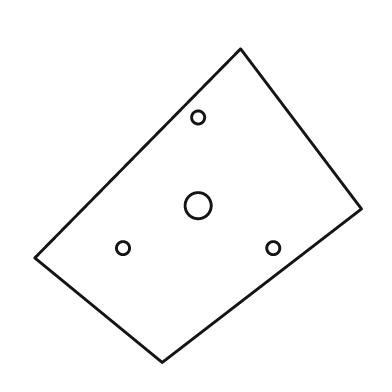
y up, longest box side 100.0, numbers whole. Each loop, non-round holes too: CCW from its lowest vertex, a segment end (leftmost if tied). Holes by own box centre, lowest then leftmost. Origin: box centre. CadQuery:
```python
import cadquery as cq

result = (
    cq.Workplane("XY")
    .moveTo(-11.0, -48.0)
    .lineTo(50.0, -1.0)
    .lineTo(13.0, 48.0)
    .lineTo(-50.0, -16.0)
    .close()
    .moveTo(-23.0, -13.0)
    .circle(2.0)
    .moveTo(23.0, -13.0)
    .circle(2.0)
    .moveTo(0.0, 0.0)
    .circle(4.0)
    .moveTo(0.0, 27.0)
    .circle(2.0)
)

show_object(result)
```